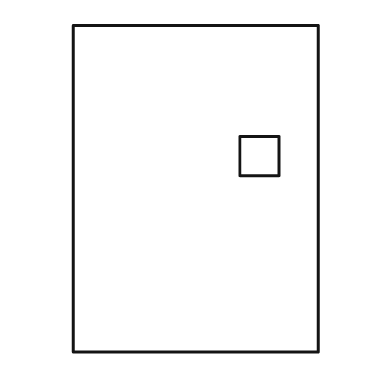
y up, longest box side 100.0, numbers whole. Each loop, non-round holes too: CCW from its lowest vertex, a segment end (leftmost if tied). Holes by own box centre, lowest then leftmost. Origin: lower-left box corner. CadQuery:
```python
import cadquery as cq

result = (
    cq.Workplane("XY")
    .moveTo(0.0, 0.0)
    .lineTo(75.0, 0.0)
    .lineTo(75.0, 100.0)
    .lineTo(0.0, 100.0)
    .close()
    .moveTo(51.0, 54.0)
    .lineTo(63.0, 54.0)
    .lineTo(63.0, 66.0)
    .lineTo(51.0, 66.0)
    .close()
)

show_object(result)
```